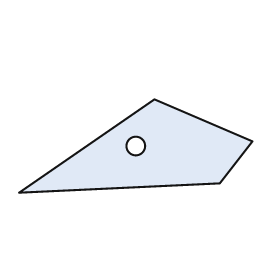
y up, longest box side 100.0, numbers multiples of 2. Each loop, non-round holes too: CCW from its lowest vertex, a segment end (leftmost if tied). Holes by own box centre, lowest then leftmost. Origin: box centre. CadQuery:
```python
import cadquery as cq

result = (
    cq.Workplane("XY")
    .moveTo(-50.0, -20.0)
    .lineTo(36.0, -16.0)
    .lineTo(50.0, 2.0)
    .lineTo(8.0, 20.0)
    .close()
    .moveTo(0.0, 0.0)
    .circle(4.0)
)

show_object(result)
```